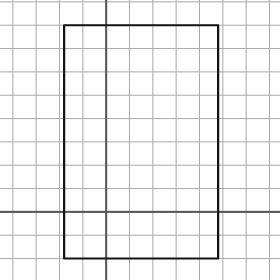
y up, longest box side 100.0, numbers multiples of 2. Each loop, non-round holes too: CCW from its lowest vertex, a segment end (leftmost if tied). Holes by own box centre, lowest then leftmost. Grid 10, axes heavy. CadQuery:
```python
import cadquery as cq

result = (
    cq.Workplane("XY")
    .moveTo(-18.0, -20.0)
    .lineTo(48.0, -20.0)
    .lineTo(48.0, 80.0)
    .lineTo(-18.0, 80.0)
    .close()
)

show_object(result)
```